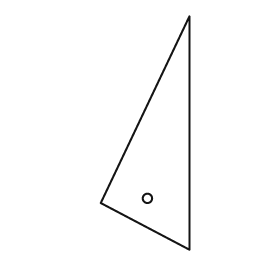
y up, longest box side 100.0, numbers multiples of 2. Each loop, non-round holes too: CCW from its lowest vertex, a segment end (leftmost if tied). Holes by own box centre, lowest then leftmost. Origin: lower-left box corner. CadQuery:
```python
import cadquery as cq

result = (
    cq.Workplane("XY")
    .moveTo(38.0, 0.0)
    .lineTo(38.0, 100.0)
    .lineTo(0.0, 20.0)
    .close()
    .moveTo(20.0, 22.0)
    .circle(2.0)
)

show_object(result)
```